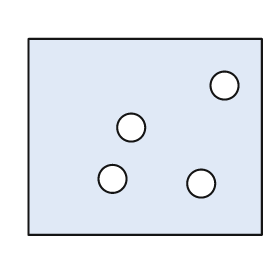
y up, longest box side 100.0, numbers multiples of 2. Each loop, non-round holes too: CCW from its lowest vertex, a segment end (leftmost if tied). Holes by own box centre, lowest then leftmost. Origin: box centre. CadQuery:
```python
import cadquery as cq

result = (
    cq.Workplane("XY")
    .moveTo(-50.0, -42.0)
    .lineTo(50.0, -42.0)
    .lineTo(50.0, 42.0)
    .lineTo(-50.0, 42.0)
    .close()
    .moveTo(24.0, -20.0)
    .circle(6.0)
    .moveTo(-14.0, -18.0)
    .circle(6.0)
    .moveTo(-6.0, 4.0)
    .circle(6.0)
    .moveTo(34.0, 22.0)
    .circle(6.0)
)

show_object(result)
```